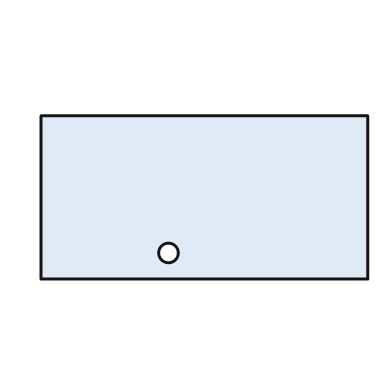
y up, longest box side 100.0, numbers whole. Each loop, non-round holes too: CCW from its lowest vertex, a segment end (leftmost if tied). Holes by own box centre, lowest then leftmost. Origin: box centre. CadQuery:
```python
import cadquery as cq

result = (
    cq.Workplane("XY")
    .moveTo(-50.0, -25.0)
    .lineTo(50.0, -25.0)
    .lineTo(50.0, 25.0)
    .lineTo(-50.0, 25.0)
    .close()
    .moveTo(-11.0, -17.0)
    .circle(3.0)
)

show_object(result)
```